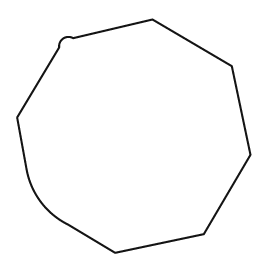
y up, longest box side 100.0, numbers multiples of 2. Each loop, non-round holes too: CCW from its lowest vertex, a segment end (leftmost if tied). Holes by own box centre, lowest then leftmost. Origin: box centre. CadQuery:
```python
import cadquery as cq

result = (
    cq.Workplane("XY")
    .moveTo(-8.0, -50.0)
    .lineTo(30.0, -42.0)
    .lineTo(50.0, -8.0)
    .lineTo(42.0, 30.0)
    .lineTo(8.0, 50.0)
    .lineTo(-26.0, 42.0)
    .threePointArc((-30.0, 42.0), (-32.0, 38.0))
    .lineTo(-50.0, 8.0)
    .lineTo(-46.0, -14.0)
    .threePointArc((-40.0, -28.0), (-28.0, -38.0))
    .close()
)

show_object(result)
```